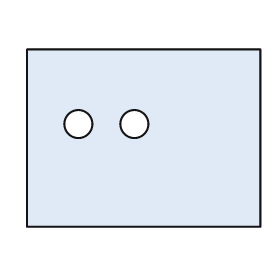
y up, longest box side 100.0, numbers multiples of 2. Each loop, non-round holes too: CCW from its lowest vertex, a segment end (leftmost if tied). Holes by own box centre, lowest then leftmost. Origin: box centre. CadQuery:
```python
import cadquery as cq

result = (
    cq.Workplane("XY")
    .moveTo(-50.0, -38.0)
    .lineTo(50.0, -38.0)
    .lineTo(50.0, 38.0)
    .lineTo(-50.0, 38.0)
    .close()
    .moveTo(-28.0, 6.0)
    .circle(6.0)
    .moveTo(-4.0, 6.0)
    .circle(6.0)
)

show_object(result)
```